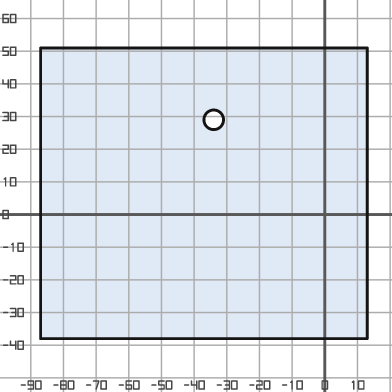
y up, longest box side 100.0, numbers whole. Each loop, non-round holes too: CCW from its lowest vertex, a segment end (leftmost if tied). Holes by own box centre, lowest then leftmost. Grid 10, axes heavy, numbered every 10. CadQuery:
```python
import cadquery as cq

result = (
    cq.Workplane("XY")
    .moveTo(-87.0, -38.0)
    .lineTo(13.0, -38.0)
    .lineTo(13.0, 51.0)
    .lineTo(-87.0, 51.0)
    .close()
    .moveTo(-34.0, 29.0)
    .circle(3.0)
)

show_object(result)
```